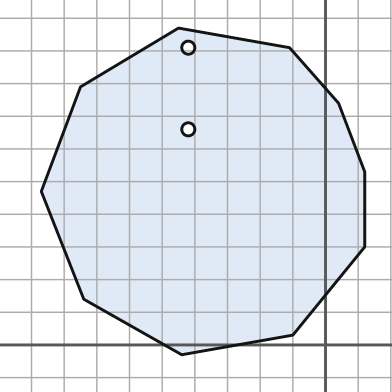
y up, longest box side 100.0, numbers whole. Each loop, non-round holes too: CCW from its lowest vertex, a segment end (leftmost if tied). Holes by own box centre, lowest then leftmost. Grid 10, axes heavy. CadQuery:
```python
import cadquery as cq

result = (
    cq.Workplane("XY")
    .moveTo(-44.0, -3.0)
    .lineTo(-10.0, 3.0)
    .lineTo(12.0, 30.0)
    .lineTo(12.0, 53.0)
    .lineTo(4.0, 74.0)
    .lineTo(-11.0, 91.0)
    .lineTo(-45.0, 97.0)
    .lineTo(-75.0, 79.0)
    .lineTo(-87.0, 47.0)
    .lineTo(-74.0, 14.0)
    .close()
    .moveTo(-42.0, 66.0)
    .circle(2.0)
    .moveTo(-42.0, 91.0)
    .circle(2.0)
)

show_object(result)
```